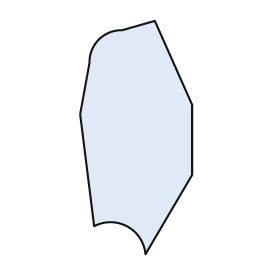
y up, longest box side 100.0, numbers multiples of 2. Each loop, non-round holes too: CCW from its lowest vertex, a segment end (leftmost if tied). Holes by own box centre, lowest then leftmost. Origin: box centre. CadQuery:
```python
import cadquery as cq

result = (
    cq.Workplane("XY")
    .moveTo(4.0, -50.0)
    .lineTo(24.0, -16.0)
    .lineTo(24.0, 14.0)
    .lineTo(8.0, 50.0)
    .lineTo(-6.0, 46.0)
    .threePointArc((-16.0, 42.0), (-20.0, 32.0))
    .lineTo(-24.0, 10.0)
    .lineTo(-18.0, -38.0)
    .threePointArc((-4.0, -38.0), (4.0, -50.0))
    .close()
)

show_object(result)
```